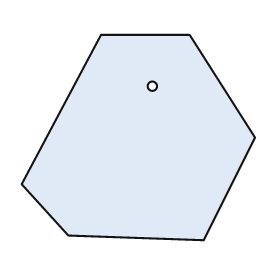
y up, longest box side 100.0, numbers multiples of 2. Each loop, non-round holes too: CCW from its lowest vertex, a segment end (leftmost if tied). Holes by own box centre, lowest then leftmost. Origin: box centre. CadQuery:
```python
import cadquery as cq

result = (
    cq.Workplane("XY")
    .moveTo(28.0, -44.0)
    .lineTo(50.0, 0.0)
    .lineTo(22.0, 44.0)
    .lineTo(-16.0, 44.0)
    .lineTo(-50.0, -20.0)
    .lineTo(-30.0, -42.0)
    .close()
    .moveTo(6.0, 22.0)
    .circle(2.0)
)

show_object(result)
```